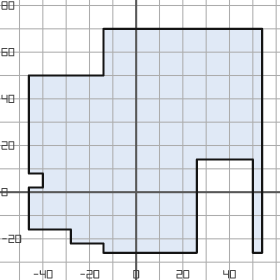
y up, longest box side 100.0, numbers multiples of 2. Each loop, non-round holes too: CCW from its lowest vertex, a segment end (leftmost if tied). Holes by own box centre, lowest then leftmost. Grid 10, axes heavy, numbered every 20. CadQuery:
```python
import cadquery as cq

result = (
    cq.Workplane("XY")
    .moveTo(-14.0, -26.0)
    .lineTo(26.0, -26.0)
    .lineTo(26.0, 14.0)
    .lineTo(50.0, 14.0)
    .lineTo(50.0, -26.0)
    .lineTo(54.0, -26.0)
    .lineTo(54.0, 70.0)
    .lineTo(-14.0, 70.0)
    .lineTo(-14.0, 50.0)
    .lineTo(-46.0, 50.0)
    .lineTo(-46.0, 8.0)
    .lineTo(-40.0, 8.0)
    .lineTo(-40.0, 2.0)
    .lineTo(-46.0, 2.0)
    .lineTo(-46.0, -16.0)
    .lineTo(-28.0, -16.0)
    .lineTo(-28.0, -22.0)
    .lineTo(-14.0, -22.0)
    .close()
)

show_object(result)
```